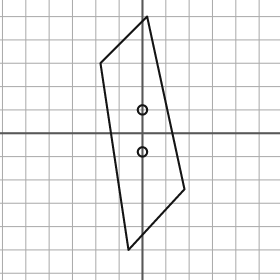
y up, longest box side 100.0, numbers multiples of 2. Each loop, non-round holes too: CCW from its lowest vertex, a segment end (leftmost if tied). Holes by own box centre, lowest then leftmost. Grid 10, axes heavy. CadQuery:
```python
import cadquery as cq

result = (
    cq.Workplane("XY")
    .moveTo(-6.0, -50.0)
    .lineTo(18.0, -24.0)
    .lineTo(2.0, 50.0)
    .lineTo(-18.0, 30.0)
    .close()
    .moveTo(0.0, -8.0)
    .circle(2.0)
    .moveTo(0.0, 10.0)
    .circle(2.0)
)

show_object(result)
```